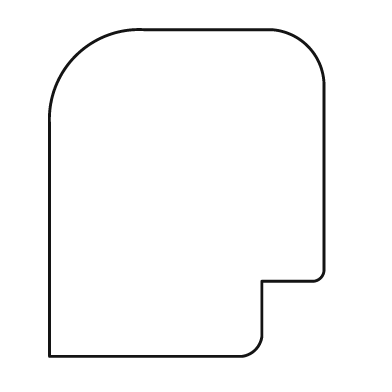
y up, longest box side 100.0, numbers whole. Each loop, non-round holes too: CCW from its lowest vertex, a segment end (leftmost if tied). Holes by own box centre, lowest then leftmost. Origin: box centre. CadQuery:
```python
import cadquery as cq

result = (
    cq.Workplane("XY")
    .moveTo(-42.0, -50.0)
    .lineTo(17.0, -50.0)
    .threePointArc((21.0, -48.0), (23.0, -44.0))
    .lineTo(23.0, -27.0)
    .lineTo(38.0, -27.0)
    .threePointArc((41.0, -26.0), (42.0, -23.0))
    .lineTo(42.0, 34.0)
    .threePointArc((37.0, 45.0), (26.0, 50.0))
    .lineTo(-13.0, 50.0)
    .threePointArc((-34.0, 42.0), (-42.0, 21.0))
    .close()
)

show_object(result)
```